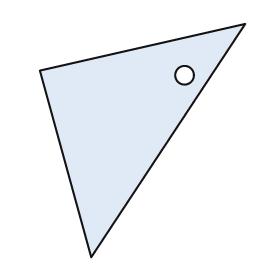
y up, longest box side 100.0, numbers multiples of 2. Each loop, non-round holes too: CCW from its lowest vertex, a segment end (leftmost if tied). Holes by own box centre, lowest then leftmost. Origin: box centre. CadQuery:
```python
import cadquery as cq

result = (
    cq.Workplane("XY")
    .moveTo(-22.0, -50.0)
    .lineTo(44.0, 50.0)
    .lineTo(-44.0, 30.0)
    .close()
    .moveTo(18.0, 28.0)
    .circle(4.0)
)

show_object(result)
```